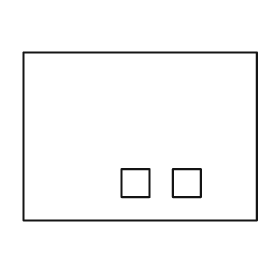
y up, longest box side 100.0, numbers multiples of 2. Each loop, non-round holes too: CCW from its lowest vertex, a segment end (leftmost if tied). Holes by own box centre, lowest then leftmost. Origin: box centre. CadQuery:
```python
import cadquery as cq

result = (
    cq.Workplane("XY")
    .moveTo(-50.0, -36.0)
    .lineTo(50.0, -36.0)
    .lineTo(50.0, 36.0)
    .lineTo(-50.0, 36.0)
    .close()
    .moveTo(-8.0, -26.0)
    .lineTo(4.0, -26.0)
    .lineTo(4.0, -14.0)
    .lineTo(-8.0, -14.0)
    .close()
    .moveTo(14.0, -26.0)
    .lineTo(26.0, -26.0)
    .lineTo(26.0, -14.0)
    .lineTo(14.0, -14.0)
    .close()
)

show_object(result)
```